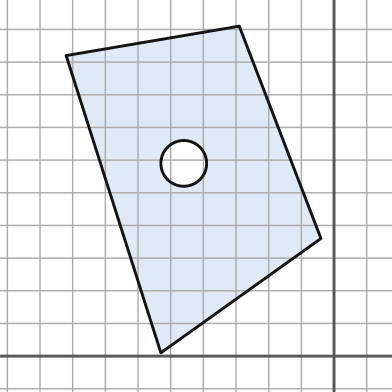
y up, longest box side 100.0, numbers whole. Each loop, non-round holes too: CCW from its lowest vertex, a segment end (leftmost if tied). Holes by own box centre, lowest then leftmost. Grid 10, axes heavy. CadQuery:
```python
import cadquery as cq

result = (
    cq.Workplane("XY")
    .moveTo(-53.0, 1.0)
    .lineTo(-4.0, 36.0)
    .lineTo(-29.0, 101.0)
    .lineTo(-82.0, 92.0)
    .close()
    .moveTo(-46.0, 59.0)
    .circle(7.0)
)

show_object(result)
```